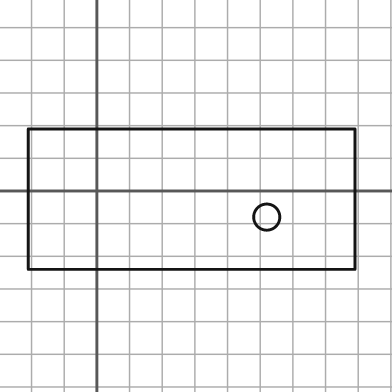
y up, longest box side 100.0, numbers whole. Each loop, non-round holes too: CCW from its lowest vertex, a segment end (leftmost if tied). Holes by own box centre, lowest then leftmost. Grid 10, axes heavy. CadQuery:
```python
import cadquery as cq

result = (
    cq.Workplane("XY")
    .moveTo(-21.0, -24.0)
    .lineTo(79.0, -24.0)
    .lineTo(79.0, 19.0)
    .lineTo(-21.0, 19.0)
    .close()
    .moveTo(52.0, -8.0)
    .circle(4.0)
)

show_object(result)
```